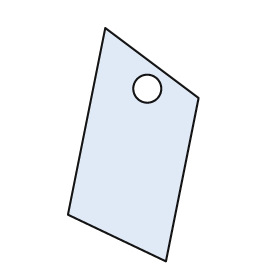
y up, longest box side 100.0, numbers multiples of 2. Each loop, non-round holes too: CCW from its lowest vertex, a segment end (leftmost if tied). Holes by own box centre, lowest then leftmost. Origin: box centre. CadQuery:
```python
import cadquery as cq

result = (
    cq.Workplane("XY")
    .moveTo(14.0, -50.0)
    .lineTo(28.0, 20.0)
    .lineTo(-12.0, 50.0)
    .lineTo(-28.0, -30.0)
    .close()
    .moveTo(6.0, 24.0)
    .circle(6.0)
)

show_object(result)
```